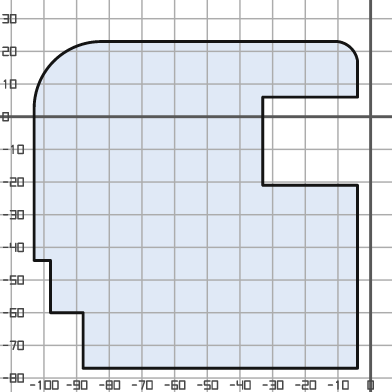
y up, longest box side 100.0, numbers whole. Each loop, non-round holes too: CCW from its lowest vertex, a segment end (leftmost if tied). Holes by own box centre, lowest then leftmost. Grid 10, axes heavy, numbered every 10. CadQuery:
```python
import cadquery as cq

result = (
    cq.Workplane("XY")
    .moveTo(-88.0, -77.0)
    .lineTo(-4.0, -77.0)
    .lineTo(-4.0, -21.0)
    .lineTo(-33.0, -21.0)
    .lineTo(-33.0, 6.0)
    .lineTo(-4.0, 6.0)
    .lineTo(-4.0, 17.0)
    .threePointArc((-6.0, 21.0), (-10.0, 23.0))
    .lineTo(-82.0, 23.0)
    .threePointArc((-97.0, 17.0), (-103.0, 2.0))
    .lineTo(-103.0, -44.0)
    .lineTo(-98.0, -44.0)
    .lineTo(-98.0, -60.0)
    .lineTo(-88.0, -60.0)
    .close()
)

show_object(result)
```